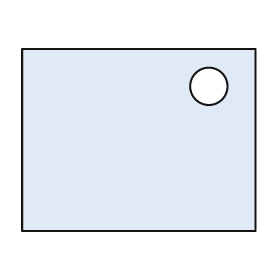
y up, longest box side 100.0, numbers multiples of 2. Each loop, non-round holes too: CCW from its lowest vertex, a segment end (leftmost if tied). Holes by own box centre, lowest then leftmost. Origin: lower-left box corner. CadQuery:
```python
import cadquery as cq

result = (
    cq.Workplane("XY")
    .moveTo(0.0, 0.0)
    .lineTo(100.0, 0.0)
    .lineTo(100.0, 78.0)
    .lineTo(0.0, 78.0)
    .close()
    .moveTo(80.0, 62.0)
    .circle(8.0)
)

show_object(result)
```